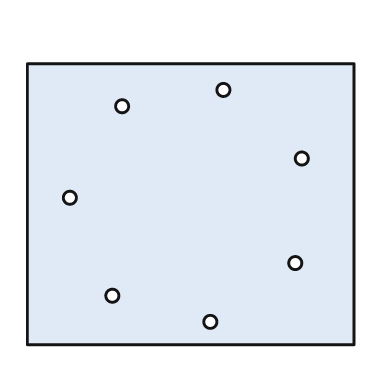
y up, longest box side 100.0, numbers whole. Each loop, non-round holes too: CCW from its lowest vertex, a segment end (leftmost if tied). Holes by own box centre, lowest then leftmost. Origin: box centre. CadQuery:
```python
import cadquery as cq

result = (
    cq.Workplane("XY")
    .moveTo(-50.0, -43.0)
    .lineTo(50.0, -43.0)
    .lineTo(50.0, 43.0)
    .lineTo(-50.0, 43.0)
    .close()
    .moveTo(6.0, -36.0)
    .circle(2.0)
    .moveTo(-24.0, -28.0)
    .circle(2.0)
    .moveTo(32.0, -18.0)
    .circle(2.0)
    .moveTo(-37.0, 2.0)
    .circle(2.0)
    .moveTo(34.0, 14.0)
    .circle(2.0)
    .moveTo(-21.0, 30.0)
    .circle(2.0)
    .moveTo(10.0, 35.0)
    .circle(2.0)
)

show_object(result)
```